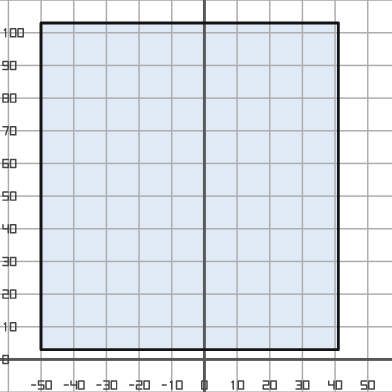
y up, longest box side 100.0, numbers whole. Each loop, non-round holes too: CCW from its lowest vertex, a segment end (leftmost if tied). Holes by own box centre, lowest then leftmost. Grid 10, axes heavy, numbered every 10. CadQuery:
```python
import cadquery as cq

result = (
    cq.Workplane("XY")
    .moveTo(-50.0, 3.0)
    .lineTo(41.0, 3.0)
    .lineTo(41.0, 103.0)
    .lineTo(-50.0, 103.0)
    .close()
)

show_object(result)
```